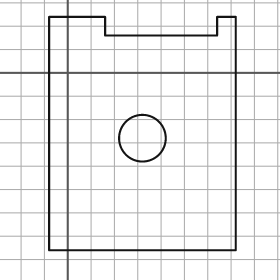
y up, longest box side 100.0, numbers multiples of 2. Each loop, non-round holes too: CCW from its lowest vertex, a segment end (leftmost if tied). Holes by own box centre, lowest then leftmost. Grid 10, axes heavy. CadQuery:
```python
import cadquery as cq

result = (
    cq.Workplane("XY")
    .moveTo(-8.0, -76.0)
    .lineTo(72.0, -76.0)
    .lineTo(72.0, 24.0)
    .lineTo(64.0, 24.0)
    .lineTo(64.0, 16.0)
    .lineTo(16.0, 16.0)
    .lineTo(16.0, 24.0)
    .lineTo(-8.0, 24.0)
    .close()
    .moveTo(32.0, -28.0)
    .circle(10.0)
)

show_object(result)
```